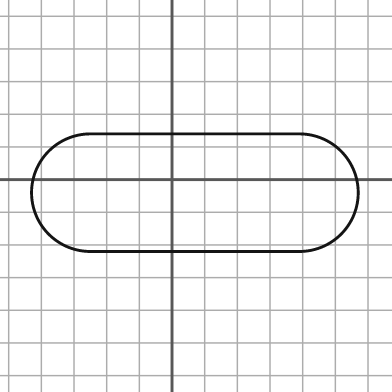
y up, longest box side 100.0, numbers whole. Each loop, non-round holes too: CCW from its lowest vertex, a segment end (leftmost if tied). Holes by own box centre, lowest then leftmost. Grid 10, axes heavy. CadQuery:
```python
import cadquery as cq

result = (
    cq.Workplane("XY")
    .moveTo(-25.0, -22.0)
    .lineTo(39.0, -22.0)
    .threePointArc((57.0, -4.0), (39.0, 14.0))
    .lineTo(-25.0, 14.0)
    .threePointArc((-43.0, -4.0), (-25.0, -22.0))
    .close()
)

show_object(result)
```